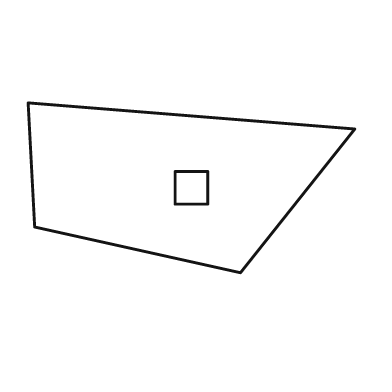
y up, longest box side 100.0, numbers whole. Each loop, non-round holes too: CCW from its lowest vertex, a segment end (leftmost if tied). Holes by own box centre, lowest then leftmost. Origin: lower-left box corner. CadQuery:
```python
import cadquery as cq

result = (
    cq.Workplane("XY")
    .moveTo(65.0, 0.0)
    .lineTo(100.0, 44.0)
    .lineTo(0.0, 52.0)
    .lineTo(2.0, 14.0)
    .close()
    .moveTo(45.0, 21.0)
    .lineTo(55.0, 21.0)
    .lineTo(55.0, 31.0)
    .lineTo(45.0, 31.0)
    .close()
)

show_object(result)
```